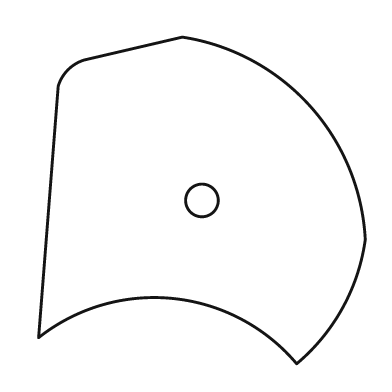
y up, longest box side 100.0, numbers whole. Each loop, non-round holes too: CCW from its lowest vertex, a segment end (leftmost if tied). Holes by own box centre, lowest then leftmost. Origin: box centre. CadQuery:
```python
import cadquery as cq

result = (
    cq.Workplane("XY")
    .moveTo(29.0, -50.0)
    .threePointArc((43.0, -33.0), (50.0, -12.0))
    .threePointArc((33.0, 29.0), (-6.0, 50.0))
    .lineTo(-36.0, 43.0)
    .threePointArc((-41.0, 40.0), (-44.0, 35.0))
    .lineTo(-50.0, -42.0)
    .threePointArc((-9.0, -30.0), (29.0, -50.0))
    .close()
    .moveTo(0.0, 0.0)
    .circle(5.0)
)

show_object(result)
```